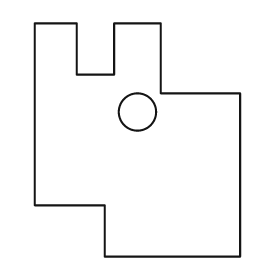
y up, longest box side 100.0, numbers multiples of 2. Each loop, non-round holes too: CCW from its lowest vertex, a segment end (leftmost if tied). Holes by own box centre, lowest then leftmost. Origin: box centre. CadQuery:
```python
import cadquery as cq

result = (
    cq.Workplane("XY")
    .moveTo(-14.0, -50.0)
    .lineTo(44.0, -50.0)
    .lineTo(44.0, 20.0)
    .lineTo(10.0, 20.0)
    .lineTo(10.0, 50.0)
    .lineTo(-10.0, 50.0)
    .lineTo(-10.0, 28.0)
    .lineTo(-26.0, 28.0)
    .lineTo(-26.0, 50.0)
    .lineTo(-44.0, 50.0)
    .lineTo(-44.0, -28.0)
    .lineTo(-14.0, -28.0)
    .close()
    .moveTo(0.0, 12.0)
    .circle(8.0)
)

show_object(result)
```